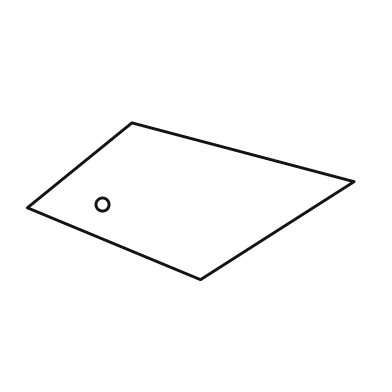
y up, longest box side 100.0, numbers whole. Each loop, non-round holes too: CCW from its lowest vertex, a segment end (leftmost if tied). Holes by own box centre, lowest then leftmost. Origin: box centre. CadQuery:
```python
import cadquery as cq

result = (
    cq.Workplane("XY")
    .moveTo(3.0, -24.0)
    .lineTo(50.0, 6.0)
    .lineTo(-18.0, 24.0)
    .lineTo(-50.0, -2.0)
    .close()
    .moveTo(-27.0, -1.0)
    .circle(2.0)
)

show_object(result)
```